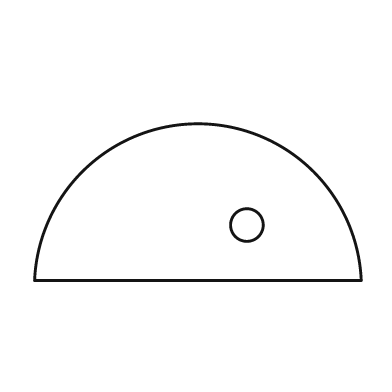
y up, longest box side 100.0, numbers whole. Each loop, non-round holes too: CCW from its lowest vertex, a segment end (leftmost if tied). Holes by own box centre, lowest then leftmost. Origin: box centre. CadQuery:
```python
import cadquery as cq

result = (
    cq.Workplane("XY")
    .moveTo(-50.0, -24.0)
    .lineTo(50.0, -24.0)
    .threePointArc((0.0, 24.0), (-50.0, -24.0))
    .close()
    .moveTo(15.0, -7.0)
    .circle(5.0)
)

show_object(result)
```